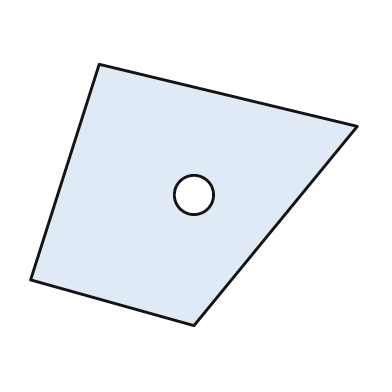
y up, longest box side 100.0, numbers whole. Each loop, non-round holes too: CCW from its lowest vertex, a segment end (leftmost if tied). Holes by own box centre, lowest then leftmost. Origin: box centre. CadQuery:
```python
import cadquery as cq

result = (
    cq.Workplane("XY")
    .moveTo(0.0, -40.0)
    .lineTo(50.0, 21.0)
    .lineTo(-29.0, 40.0)
    .lineTo(-50.0, -26.0)
    .close()
    .moveTo(0.0, 0.0)
    .circle(6.0)
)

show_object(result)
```